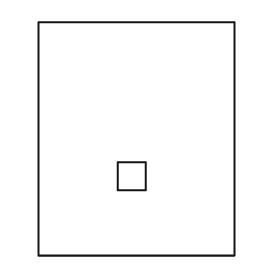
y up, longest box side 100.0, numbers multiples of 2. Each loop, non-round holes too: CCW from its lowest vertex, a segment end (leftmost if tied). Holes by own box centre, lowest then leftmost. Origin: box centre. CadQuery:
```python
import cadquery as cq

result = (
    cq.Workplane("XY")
    .moveTo(-42.0, -50.0)
    .lineTo(42.0, -50.0)
    .lineTo(42.0, 50.0)
    .lineTo(-42.0, 50.0)
    .close()
    .moveTo(-8.0, -22.0)
    .lineTo(4.0, -22.0)
    .lineTo(4.0, -10.0)
    .lineTo(-8.0, -10.0)
    .close()
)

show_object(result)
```